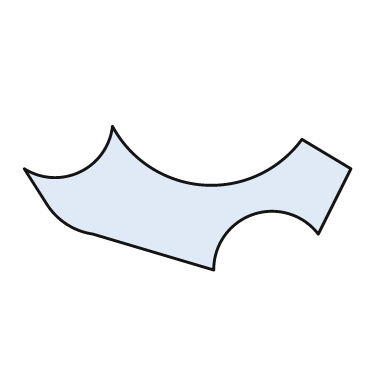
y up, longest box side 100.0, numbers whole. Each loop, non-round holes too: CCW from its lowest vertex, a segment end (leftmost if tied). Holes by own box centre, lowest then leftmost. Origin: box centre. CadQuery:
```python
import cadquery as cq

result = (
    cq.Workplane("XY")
    .moveTo(8.0, -22.0)
    .threePointArc((20.0, -5.0), (40.0, -11.0))
    .lineTo(50.0, 9.0)
    .lineTo(35.0, 18.0)
    .threePointArc((5.0, 4.0), (-23.0, 22.0))
    .threePointArc((-33.0, 8.0), (-50.0, 9.0))
    .lineTo(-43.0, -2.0)
    .threePointArc((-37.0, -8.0), (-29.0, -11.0))
    .close()
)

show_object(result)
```